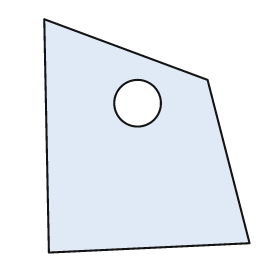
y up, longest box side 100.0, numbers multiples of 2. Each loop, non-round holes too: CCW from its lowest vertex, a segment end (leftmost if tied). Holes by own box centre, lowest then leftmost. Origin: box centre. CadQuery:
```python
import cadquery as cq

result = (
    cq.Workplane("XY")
    .moveTo(-42.0, -50.0)
    .lineTo(44.0, -46.0)
    .lineTo(26.0, 24.0)
    .lineTo(-44.0, 50.0)
    .close()
    .moveTo(-4.0, 14.0)
    .circle(10.0)
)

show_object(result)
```